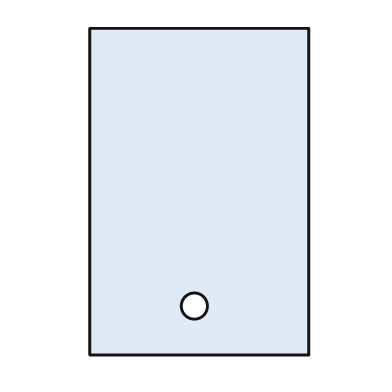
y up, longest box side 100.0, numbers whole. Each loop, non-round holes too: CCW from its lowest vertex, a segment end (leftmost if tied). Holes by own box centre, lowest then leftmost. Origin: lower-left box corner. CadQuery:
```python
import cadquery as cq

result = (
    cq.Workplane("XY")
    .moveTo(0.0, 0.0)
    .lineTo(67.0, 0.0)
    .lineTo(67.0, 100.0)
    .lineTo(0.0, 100.0)
    .close()
    .moveTo(32.0, 15.0)
    .circle(4.0)
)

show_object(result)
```